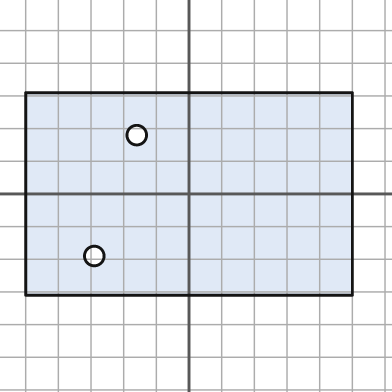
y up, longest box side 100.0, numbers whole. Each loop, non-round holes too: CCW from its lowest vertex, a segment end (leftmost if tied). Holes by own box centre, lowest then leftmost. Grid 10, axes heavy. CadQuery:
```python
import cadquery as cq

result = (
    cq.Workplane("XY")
    .moveTo(-50.0, -31.0)
    .lineTo(50.0, -31.0)
    .lineTo(50.0, 31.0)
    .lineTo(-50.0, 31.0)
    .close()
    .moveTo(-29.0, -19.0)
    .circle(3.0)
    .moveTo(-16.0, 18.0)
    .circle(3.0)
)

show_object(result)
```